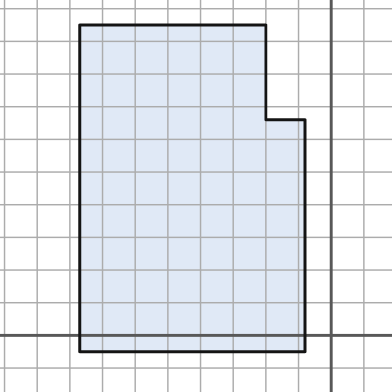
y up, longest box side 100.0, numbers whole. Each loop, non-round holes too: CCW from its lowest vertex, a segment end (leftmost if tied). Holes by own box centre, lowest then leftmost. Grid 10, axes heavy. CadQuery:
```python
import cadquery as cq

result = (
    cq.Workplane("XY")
    .moveTo(-77.0, -5.0)
    .lineTo(-8.0, -5.0)
    .lineTo(-8.0, 66.0)
    .lineTo(-20.0, 66.0)
    .lineTo(-20.0, 95.0)
    .lineTo(-77.0, 95.0)
    .close()
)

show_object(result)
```